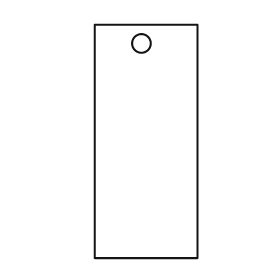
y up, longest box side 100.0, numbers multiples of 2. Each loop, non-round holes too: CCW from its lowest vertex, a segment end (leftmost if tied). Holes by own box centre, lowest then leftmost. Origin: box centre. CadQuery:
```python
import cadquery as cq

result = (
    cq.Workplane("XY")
    .moveTo(-22.0, -50.0)
    .lineTo(22.0, -50.0)
    .lineTo(22.0, 50.0)
    .lineTo(-22.0, 50.0)
    .close()
    .moveTo(-2.0, 42.0)
    .circle(4.0)
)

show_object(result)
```